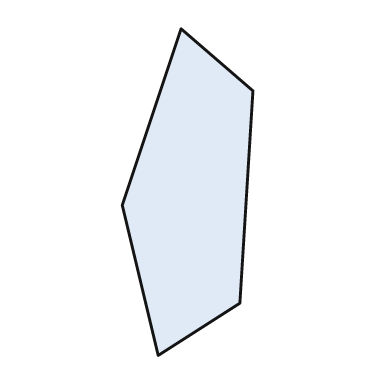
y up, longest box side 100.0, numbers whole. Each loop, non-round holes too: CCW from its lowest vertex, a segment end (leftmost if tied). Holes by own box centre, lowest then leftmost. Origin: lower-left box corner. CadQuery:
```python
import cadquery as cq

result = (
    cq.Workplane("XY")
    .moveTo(11.0, 0.0)
    .lineTo(36.0, 16.0)
    .lineTo(40.0, 81.0)
    .lineTo(18.0, 100.0)
    .lineTo(0.0, 46.0)
    .close()
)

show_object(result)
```